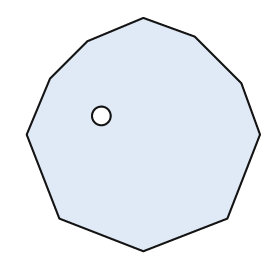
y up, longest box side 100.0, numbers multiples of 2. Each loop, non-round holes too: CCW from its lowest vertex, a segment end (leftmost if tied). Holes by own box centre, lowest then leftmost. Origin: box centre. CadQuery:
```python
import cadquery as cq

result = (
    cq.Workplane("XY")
    .moveTo(0.0, -50.0)
    .lineTo(36.0, -36.0)
    .lineTo(50.0, 0.0)
    .lineTo(42.0, 22.0)
    .lineTo(22.0, 42.0)
    .lineTo(0.0, 50.0)
    .lineTo(-24.0, 40.0)
    .lineTo(-40.0, 24.0)
    .lineTo(-50.0, 0.0)
    .lineTo(-36.0, -36.0)
    .close()
    .moveTo(-18.0, 8.0)
    .circle(4.0)
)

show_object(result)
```